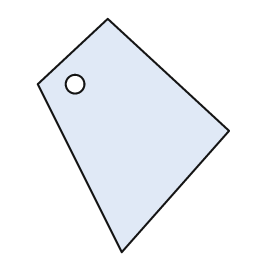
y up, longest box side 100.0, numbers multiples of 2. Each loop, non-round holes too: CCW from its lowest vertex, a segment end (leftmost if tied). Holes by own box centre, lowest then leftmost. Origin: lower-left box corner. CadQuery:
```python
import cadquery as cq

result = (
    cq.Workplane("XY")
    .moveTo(36.0, 0.0)
    .lineTo(82.0, 52.0)
    .lineTo(30.0, 100.0)
    .lineTo(0.0, 72.0)
    .close()
    .moveTo(16.0, 72.0)
    .circle(4.0)
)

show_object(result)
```